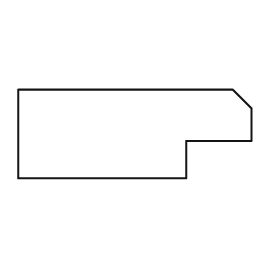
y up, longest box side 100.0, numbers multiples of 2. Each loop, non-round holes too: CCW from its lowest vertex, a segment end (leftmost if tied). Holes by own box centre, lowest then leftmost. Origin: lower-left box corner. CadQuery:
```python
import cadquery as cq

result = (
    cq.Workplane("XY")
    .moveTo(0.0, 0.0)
    .lineTo(72.0, 0.0)
    .lineTo(72.0, 16.0)
    .lineTo(100.0, 16.0)
    .lineTo(100.0, 30.0)
    .lineTo(92.0, 38.0)
    .lineTo(0.0, 38.0)
    .close()
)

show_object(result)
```